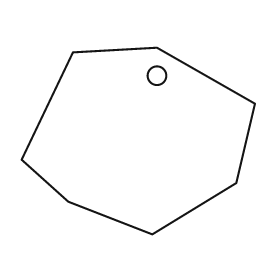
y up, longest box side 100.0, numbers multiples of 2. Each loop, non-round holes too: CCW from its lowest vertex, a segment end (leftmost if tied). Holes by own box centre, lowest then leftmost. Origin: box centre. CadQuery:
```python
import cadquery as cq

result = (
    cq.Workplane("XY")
    .moveTo(6.0, -40.0)
    .lineTo(42.0, -18.0)
    .lineTo(50.0, 16.0)
    .lineTo(8.0, 40.0)
    .lineTo(-28.0, 38.0)
    .lineTo(-50.0, -8.0)
    .lineTo(-30.0, -26.0)
    .close()
    .moveTo(8.0, 28.0)
    .circle(4.0)
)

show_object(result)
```